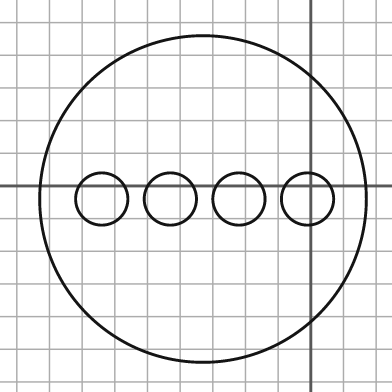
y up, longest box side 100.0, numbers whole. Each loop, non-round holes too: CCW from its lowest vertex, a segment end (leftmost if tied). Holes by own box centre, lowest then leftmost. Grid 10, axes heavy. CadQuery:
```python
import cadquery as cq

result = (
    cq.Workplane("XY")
    .moveTo(-33.0, -4.0)
    .circle(50.0)
    .moveTo(-64.0, -4.0)
    .circle(8.0)
    .moveTo(-43.0, -4.0)
    .circle(8.0)
    .moveTo(-22.0, -4.0)
    .circle(8.0)
    .moveTo(-1.0, -4.0)
    .circle(8.0)
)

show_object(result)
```